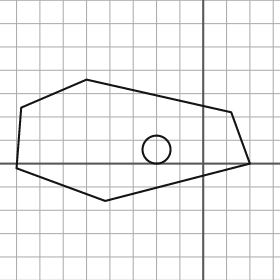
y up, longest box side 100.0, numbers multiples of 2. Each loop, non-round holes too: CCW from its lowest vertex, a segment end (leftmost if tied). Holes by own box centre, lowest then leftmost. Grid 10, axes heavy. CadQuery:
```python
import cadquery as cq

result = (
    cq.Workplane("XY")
    .moveTo(-42.0, -16.0)
    .lineTo(20.0, 0.0)
    .lineTo(12.0, 22.0)
    .lineTo(-50.0, 36.0)
    .lineTo(-78.0, 24.0)
    .lineTo(-80.0, -2.0)
    .close()
    .moveTo(-20.0, 6.0)
    .circle(6.0)
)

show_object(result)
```